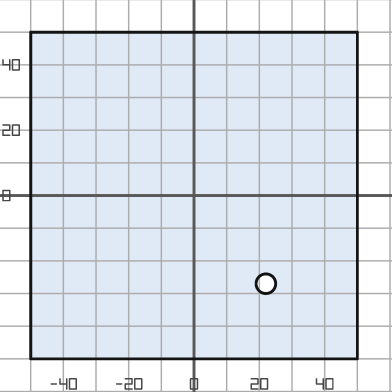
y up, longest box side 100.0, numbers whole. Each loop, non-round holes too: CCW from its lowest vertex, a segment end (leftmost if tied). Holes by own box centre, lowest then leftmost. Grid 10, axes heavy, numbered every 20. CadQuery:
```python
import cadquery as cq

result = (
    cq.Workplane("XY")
    .moveTo(-50.0, -50.0)
    .lineTo(50.0, -50.0)
    .lineTo(50.0, 50.0)
    .lineTo(-50.0, 50.0)
    .close()
    .moveTo(22.0, -27.0)
    .circle(3.0)
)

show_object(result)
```